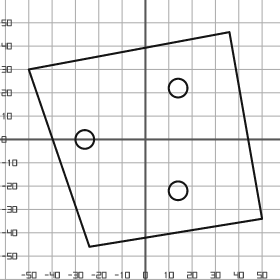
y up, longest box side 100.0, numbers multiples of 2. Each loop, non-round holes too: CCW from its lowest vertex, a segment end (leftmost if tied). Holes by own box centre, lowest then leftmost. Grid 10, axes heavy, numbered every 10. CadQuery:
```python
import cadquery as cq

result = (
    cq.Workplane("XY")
    .moveTo(-24.0, -46.0)
    .lineTo(50.0, -34.0)
    .lineTo(36.0, 46.0)
    .lineTo(-50.0, 30.0)
    .close()
    .moveTo(14.0, -22.0)
    .circle(4.0)
    .moveTo(-26.0, 0.0)
    .circle(4.0)
    .moveTo(14.0, 22.0)
    .circle(4.0)
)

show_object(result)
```